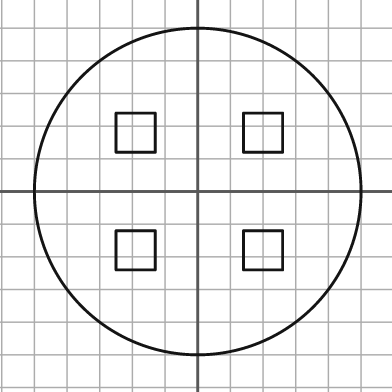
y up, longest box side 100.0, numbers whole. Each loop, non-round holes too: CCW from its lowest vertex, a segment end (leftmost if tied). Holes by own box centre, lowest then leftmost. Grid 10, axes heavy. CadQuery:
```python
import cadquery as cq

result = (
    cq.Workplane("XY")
    .moveTo(0.0, 0.0)
    .circle(50.0)
    .moveTo(-25.0, -24.0)
    .lineTo(-13.0, -24.0)
    .lineTo(-13.0, -12.0)
    .lineTo(-25.0, -12.0)
    .close()
    .moveTo(14.0, -24.0)
    .lineTo(26.0, -24.0)
    .lineTo(26.0, -12.0)
    .lineTo(14.0, -12.0)
    .close()
    .moveTo(-25.0, 12.0)
    .lineTo(-13.0, 12.0)
    .lineTo(-13.0, 24.0)
    .lineTo(-25.0, 24.0)
    .close()
    .moveTo(14.0, 12.0)
    .lineTo(26.0, 12.0)
    .lineTo(26.0, 24.0)
    .lineTo(14.0, 24.0)
    .close()
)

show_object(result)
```